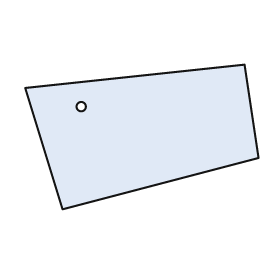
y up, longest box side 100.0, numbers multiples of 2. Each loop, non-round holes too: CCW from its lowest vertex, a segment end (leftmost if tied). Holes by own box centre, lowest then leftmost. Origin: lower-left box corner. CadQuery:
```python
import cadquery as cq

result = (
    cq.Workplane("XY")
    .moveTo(16.0, 0.0)
    .lineTo(100.0, 22.0)
    .lineTo(94.0, 62.0)
    .lineTo(0.0, 52.0)
    .close()
    .moveTo(24.0, 44.0)
    .circle(2.0)
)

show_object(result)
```